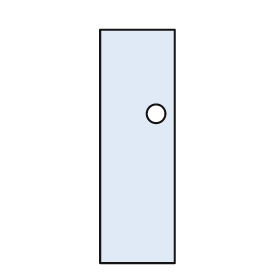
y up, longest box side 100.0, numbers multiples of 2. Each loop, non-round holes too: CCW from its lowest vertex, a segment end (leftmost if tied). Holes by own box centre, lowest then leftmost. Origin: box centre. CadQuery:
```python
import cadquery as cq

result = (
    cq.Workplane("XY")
    .moveTo(-16.0, -50.0)
    .lineTo(16.0, -50.0)
    .lineTo(16.0, 50.0)
    .lineTo(-16.0, 50.0)
    .close()
    .moveTo(8.0, 14.0)
    .circle(4.0)
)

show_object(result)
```